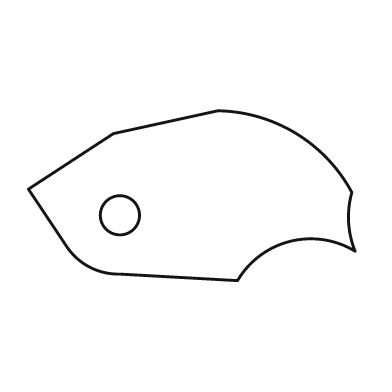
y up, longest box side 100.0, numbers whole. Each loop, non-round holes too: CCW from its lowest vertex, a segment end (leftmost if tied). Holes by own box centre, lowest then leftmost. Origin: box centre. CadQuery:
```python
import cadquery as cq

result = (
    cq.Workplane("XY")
    .moveTo(14.0, -26.0)
    .threePointArc((30.0, -14.0), (50.0, -17.0))
    .threePointArc((48.0, -8.0), (49.0, 1.0))
    .threePointArc((32.0, 19.0), (8.0, 26.0))
    .lineTo(-24.0, 19.0)
    .lineTo(-50.0, 2.0)
    .lineTo(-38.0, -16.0)
    .threePointArc((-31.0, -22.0), (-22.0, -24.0))
    .close()
    .moveTo(-22.0, -6.0)
    .circle(6.0)
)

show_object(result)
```